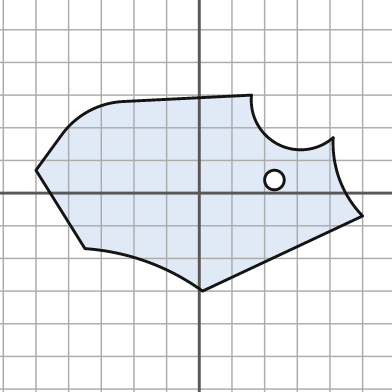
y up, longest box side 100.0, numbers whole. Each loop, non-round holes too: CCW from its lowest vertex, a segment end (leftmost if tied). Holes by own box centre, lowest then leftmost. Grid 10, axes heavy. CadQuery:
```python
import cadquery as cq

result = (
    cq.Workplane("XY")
    .moveTo(1.0, -30.0)
    .lineTo(50.0, -7.0)
    .threePointArc((43.0, 4.0), (41.0, 17.0))
    .threePointArc((24.0, 15.0), (16.0, 30.0))
    .lineTo(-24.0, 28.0)
    .threePointArc((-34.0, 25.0), (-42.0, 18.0))
    .lineTo(-50.0, 7.0)
    .lineTo(-35.0, -17.0)
    .threePointArc((-16.0, -21.0), (1.0, -30.0))
    .close()
    .moveTo(23.0, 4.0)
    .circle(3.0)
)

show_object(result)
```